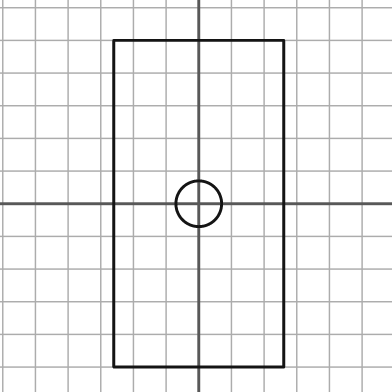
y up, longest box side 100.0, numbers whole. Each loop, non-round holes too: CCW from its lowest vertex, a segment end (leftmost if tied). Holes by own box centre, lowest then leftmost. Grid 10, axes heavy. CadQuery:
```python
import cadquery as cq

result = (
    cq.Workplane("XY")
    .moveTo(-26.0, -50.0)
    .lineTo(26.0, -50.0)
    .lineTo(26.0, 50.0)
    .lineTo(-26.0, 50.0)
    .close()
    .moveTo(0.0, 0.0)
    .circle(7.0)
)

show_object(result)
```